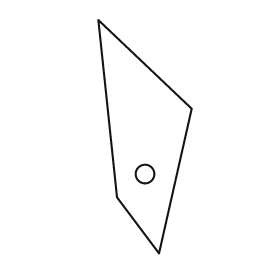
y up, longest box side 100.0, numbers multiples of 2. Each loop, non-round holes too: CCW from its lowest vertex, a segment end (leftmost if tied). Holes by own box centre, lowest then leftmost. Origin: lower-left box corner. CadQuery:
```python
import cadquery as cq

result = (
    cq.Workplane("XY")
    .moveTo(26.0, 0.0)
    .lineTo(40.0, 62.0)
    .lineTo(0.0, 100.0)
    .lineTo(8.0, 24.0)
    .close()
    .moveTo(20.0, 34.0)
    .circle(4.0)
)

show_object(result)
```